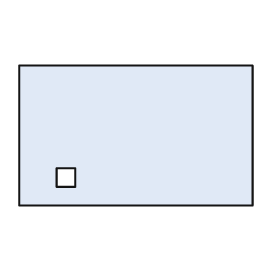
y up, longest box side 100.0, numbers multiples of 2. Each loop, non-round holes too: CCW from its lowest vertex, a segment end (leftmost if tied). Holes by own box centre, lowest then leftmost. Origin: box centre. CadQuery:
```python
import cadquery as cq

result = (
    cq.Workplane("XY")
    .moveTo(-50.0, -30.0)
    .lineTo(50.0, -30.0)
    .lineTo(50.0, 30.0)
    .lineTo(-50.0, 30.0)
    .close()
    .moveTo(-34.0, -22.0)
    .lineTo(-26.0, -22.0)
    .lineTo(-26.0, -14.0)
    .lineTo(-34.0, -14.0)
    .close()
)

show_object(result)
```